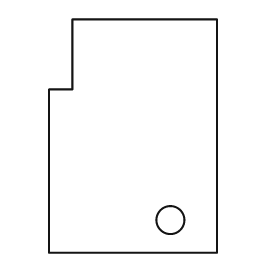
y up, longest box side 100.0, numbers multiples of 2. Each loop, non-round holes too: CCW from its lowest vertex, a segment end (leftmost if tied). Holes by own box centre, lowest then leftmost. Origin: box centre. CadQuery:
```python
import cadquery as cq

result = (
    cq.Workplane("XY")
    .moveTo(-36.0, -50.0)
    .lineTo(36.0, -50.0)
    .lineTo(36.0, 50.0)
    .lineTo(-26.0, 50.0)
    .lineTo(-26.0, 20.0)
    .lineTo(-36.0, 20.0)
    .close()
    .moveTo(16.0, -36.0)
    .circle(6.0)
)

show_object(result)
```